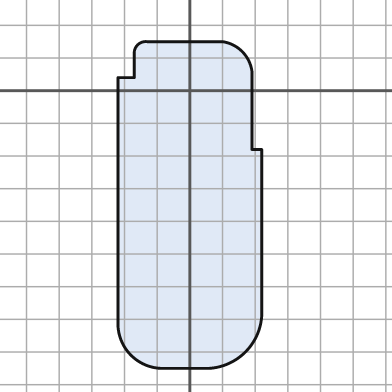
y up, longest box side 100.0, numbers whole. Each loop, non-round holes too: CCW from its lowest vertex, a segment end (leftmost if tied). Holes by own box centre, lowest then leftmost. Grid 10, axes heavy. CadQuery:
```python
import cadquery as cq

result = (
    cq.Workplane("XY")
    .moveTo(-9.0, -85.0)
    .lineTo(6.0, -85.0)
    .threePointArc((17.0, -80.0), (22.0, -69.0))
    .lineTo(22.0, -18.0)
    .lineTo(19.0, -18.0)
    .lineTo(19.0, 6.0)
    .threePointArc((16.0, 12.0), (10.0, 15.0))
    .lineTo(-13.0, 15.0)
    .threePointArc((-16.0, 14.0), (-17.0, 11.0))
    .lineTo(-17.0, 4.0)
    .lineTo(-22.0, 4.0)
    .lineTo(-22.0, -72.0)
    .threePointArc((-18.0, -81.0), (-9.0, -85.0))
    .close()
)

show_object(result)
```